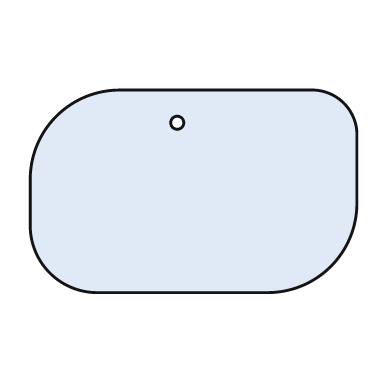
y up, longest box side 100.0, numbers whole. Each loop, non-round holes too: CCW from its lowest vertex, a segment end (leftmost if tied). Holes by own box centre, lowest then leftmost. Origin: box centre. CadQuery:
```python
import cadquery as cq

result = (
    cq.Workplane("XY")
    .moveTo(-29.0, -31.0)
    .lineTo(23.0, -31.0)
    .threePointArc((42.0, -23.0), (50.0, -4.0))
    .lineTo(50.0, 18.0)
    .threePointArc((46.0, 27.0), (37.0, 31.0))
    .lineTo(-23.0, 31.0)
    .threePointArc((-42.0, 23.0), (-50.0, 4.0))
    .lineTo(-50.0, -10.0)
    .threePointArc((-44.0, -25.0), (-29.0, -31.0))
    .close()
    .moveTo(-5.0, 21.0)
    .circle(2.0)
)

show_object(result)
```